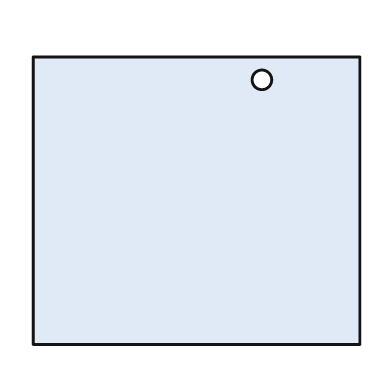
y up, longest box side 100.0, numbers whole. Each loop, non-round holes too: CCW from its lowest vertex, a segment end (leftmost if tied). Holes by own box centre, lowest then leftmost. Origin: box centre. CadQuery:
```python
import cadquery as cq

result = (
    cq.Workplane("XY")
    .moveTo(-50.0, -44.0)
    .lineTo(50.0, -44.0)
    .lineTo(50.0, 44.0)
    .lineTo(-50.0, 44.0)
    .close()
    .moveTo(20.0, 37.0)
    .circle(3.0)
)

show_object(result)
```